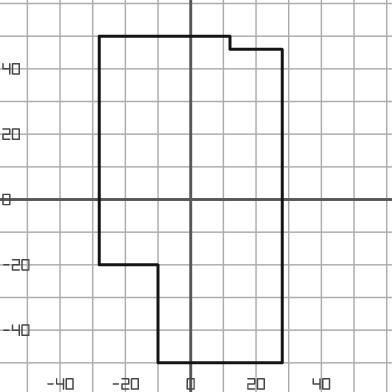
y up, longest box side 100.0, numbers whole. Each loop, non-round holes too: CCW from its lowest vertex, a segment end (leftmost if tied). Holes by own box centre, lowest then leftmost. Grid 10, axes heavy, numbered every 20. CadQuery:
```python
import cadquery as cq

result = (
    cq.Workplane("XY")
    .moveTo(-10.0, -50.0)
    .lineTo(28.0, -50.0)
    .lineTo(28.0, 46.0)
    .lineTo(12.0, 46.0)
    .lineTo(12.0, 50.0)
    .lineTo(-28.0, 50.0)
    .lineTo(-28.0, -20.0)
    .lineTo(-10.0, -20.0)
    .close()
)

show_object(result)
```